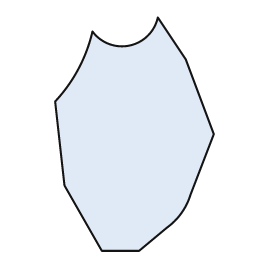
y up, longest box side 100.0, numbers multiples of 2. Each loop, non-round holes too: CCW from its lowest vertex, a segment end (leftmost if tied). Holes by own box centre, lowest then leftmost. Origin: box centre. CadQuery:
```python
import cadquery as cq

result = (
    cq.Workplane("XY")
    .moveTo(-14.0, -50.0)
    .lineTo(2.0, -50.0)
    .lineTo(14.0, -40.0)
    .threePointArc((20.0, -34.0), (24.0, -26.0))
    .lineTo(34.0, 0.0)
    .lineTo(22.0, 32.0)
    .lineTo(10.0, 50.0)
    .threePointArc((-2.0, 38.0), (-18.0, 44.0))
    .threePointArc((-24.0, 28.0), (-34.0, 14.0))
    .lineTo(-30.0, -22.0)
    .close()
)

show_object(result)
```